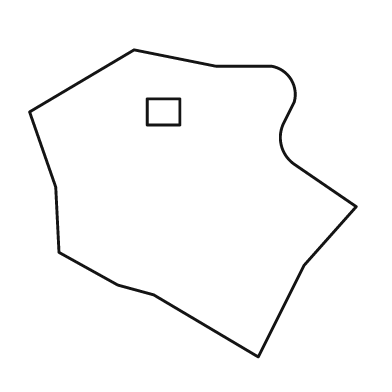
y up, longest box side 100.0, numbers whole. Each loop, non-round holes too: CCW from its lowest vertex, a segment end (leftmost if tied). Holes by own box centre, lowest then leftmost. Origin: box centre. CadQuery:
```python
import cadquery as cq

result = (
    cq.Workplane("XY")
    .moveTo(20.0, -47.0)
    .lineTo(34.0, -19.0)
    .lineTo(50.0, -1.0)
    .lineTo(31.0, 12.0)
    .threePointArc((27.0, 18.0), (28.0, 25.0))
    .lineTo(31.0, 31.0)
    .threePointArc((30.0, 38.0), (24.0, 42.0))
    .lineTo(7.0, 42.0)
    .lineTo(-18.0, 47.0)
    .lineTo(-50.0, 28.0)
    .lineTo(-42.0, 5.0)
    .lineTo(-41.0, -15.0)
    .lineTo(-23.0, -25.0)
    .lineTo(-12.0, -28.0)
    .close()
    .moveTo(-14.0, 24.0)
    .lineTo(-4.0, 24.0)
    .lineTo(-4.0, 32.0)
    .lineTo(-14.0, 32.0)
    .close()
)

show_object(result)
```